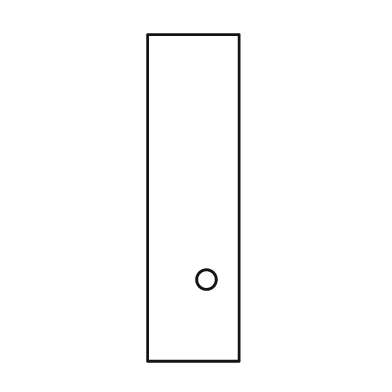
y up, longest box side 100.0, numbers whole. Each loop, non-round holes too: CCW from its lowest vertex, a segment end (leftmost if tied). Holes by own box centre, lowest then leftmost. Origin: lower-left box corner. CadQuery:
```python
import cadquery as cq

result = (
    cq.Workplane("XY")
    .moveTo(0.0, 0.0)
    .lineTo(28.0, 0.0)
    .lineTo(28.0, 100.0)
    .lineTo(0.0, 100.0)
    .close()
    .moveTo(18.0, 25.0)
    .circle(3.0)
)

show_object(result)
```